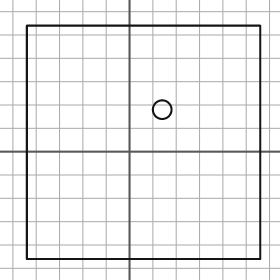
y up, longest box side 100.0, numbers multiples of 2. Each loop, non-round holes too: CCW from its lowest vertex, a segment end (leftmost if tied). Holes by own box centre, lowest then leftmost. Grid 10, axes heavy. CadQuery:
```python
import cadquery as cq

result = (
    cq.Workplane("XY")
    .moveTo(-44.0, -46.0)
    .lineTo(56.0, -46.0)
    .lineTo(56.0, 54.0)
    .lineTo(-44.0, 54.0)
    .close()
    .moveTo(14.0, 18.0)
    .circle(4.0)
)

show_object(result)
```